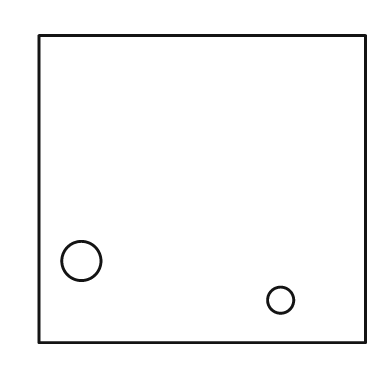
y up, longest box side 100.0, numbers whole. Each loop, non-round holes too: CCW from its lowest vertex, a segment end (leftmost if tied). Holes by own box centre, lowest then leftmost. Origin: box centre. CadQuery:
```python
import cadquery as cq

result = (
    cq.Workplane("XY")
    .moveTo(-50.0, -47.0)
    .lineTo(50.0, -47.0)
    .lineTo(50.0, 47.0)
    .lineTo(-50.0, 47.0)
    .close()
    .moveTo(24.0, -34.0)
    .circle(4.0)
    .moveTo(-37.0, -22.0)
    .circle(6.0)
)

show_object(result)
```